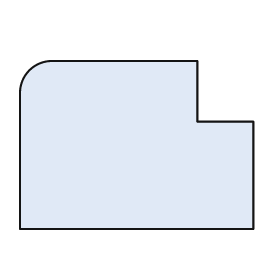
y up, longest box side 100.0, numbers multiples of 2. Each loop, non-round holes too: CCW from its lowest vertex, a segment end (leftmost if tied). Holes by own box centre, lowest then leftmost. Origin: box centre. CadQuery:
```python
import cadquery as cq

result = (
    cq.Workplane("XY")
    .moveTo(-50.0, -36.0)
    .lineTo(50.0, -36.0)
    .lineTo(50.0, 10.0)
    .lineTo(26.0, 10.0)
    .lineTo(26.0, 36.0)
    .lineTo(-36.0, 36.0)
    .threePointArc((-46.0, 32.0), (-50.0, 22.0))
    .close()
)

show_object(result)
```